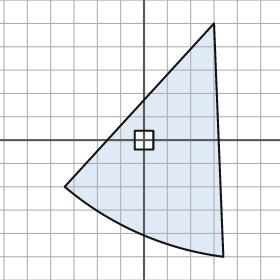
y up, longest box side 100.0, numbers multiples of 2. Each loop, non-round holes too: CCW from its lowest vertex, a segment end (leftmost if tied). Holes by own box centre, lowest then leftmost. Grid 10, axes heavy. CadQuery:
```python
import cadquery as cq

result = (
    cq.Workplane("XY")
    .moveTo(34.0, -50.0)
    .lineTo(30.0, 50.0)
    .lineTo(-34.0, -20.0)
    .threePointArc((-2.0, -40.0), (34.0, -50.0))
    .close()
    .moveTo(-4.0, -4.0)
    .lineTo(4.0, -4.0)
    .lineTo(4.0, 4.0)
    .lineTo(-4.0, 4.0)
    .close()
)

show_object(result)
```